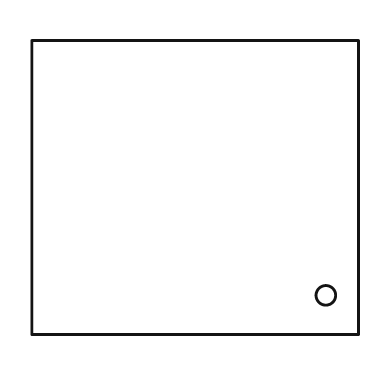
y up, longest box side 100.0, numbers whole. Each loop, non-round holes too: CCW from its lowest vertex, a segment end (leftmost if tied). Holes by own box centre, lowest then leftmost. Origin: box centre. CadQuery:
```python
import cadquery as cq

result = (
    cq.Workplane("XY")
    .moveTo(-50.0, -45.0)
    .lineTo(50.0, -45.0)
    .lineTo(50.0, 45.0)
    .lineTo(-50.0, 45.0)
    .close()
    .moveTo(40.0, -33.0)
    .circle(3.0)
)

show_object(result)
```